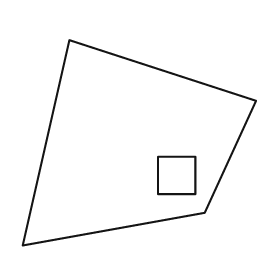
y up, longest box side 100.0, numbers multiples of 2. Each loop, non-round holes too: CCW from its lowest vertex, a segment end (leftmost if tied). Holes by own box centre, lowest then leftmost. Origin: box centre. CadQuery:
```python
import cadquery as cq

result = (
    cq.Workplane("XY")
    .moveTo(-50.0, -44.0)
    .lineTo(28.0, -30.0)
    .lineTo(50.0, 18.0)
    .lineTo(-30.0, 44.0)
    .close()
    .moveTo(8.0, -22.0)
    .lineTo(24.0, -22.0)
    .lineTo(24.0, -6.0)
    .lineTo(8.0, -6.0)
    .close()
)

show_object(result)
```